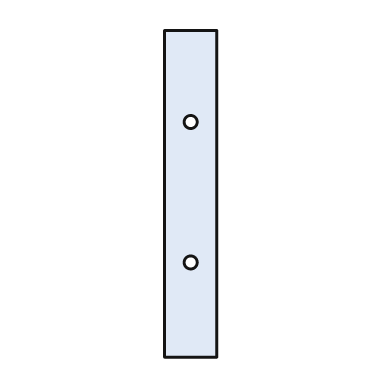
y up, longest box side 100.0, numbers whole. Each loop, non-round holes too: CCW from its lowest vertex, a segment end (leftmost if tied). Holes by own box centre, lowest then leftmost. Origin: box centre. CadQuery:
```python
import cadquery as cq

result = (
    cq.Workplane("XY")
    .moveTo(-8.0, -50.0)
    .lineTo(8.0, -50.0)
    .lineTo(8.0, 50.0)
    .lineTo(-8.0, 50.0)
    .close()
    .moveTo(0.0, -21.0)
    .circle(2.0)
    .moveTo(0.0, 22.0)
    .circle(2.0)
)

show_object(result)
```